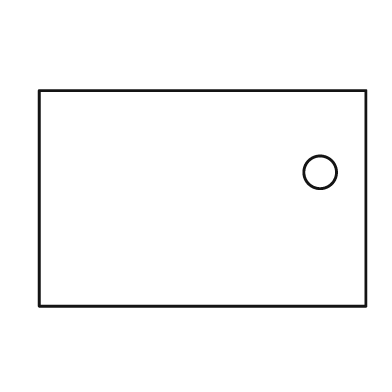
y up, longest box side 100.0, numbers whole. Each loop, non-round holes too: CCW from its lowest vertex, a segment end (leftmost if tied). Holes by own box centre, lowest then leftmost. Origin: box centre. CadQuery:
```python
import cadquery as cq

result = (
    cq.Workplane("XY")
    .moveTo(-50.0, -33.0)
    .lineTo(50.0, -33.0)
    .lineTo(50.0, 33.0)
    .lineTo(-50.0, 33.0)
    .close()
    .moveTo(36.0, 8.0)
    .circle(5.0)
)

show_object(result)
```